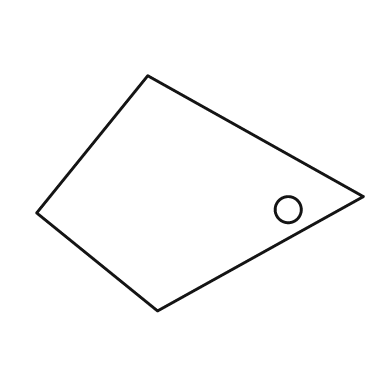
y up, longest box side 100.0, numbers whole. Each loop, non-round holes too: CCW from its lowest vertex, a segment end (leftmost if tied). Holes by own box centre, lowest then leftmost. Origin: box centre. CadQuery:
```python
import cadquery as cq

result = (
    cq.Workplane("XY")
    .moveTo(-13.0, -36.0)
    .lineTo(50.0, -1.0)
    .lineTo(-16.0, 36.0)
    .lineTo(-50.0, -6.0)
    .close()
    .moveTo(27.0, -5.0)
    .circle(4.0)
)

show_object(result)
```